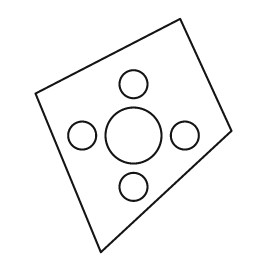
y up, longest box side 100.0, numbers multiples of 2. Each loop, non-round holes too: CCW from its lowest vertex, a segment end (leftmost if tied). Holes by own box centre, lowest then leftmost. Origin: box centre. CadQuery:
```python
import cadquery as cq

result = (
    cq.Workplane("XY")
    .moveTo(-14.0, -50.0)
    .lineTo(42.0, 2.0)
    .lineTo(20.0, 50.0)
    .lineTo(-42.0, 18.0)
    .close()
    .moveTo(0.0, -22.0)
    .circle(6.0)
    .moveTo(-22.0, 0.0)
    .circle(6.0)
    .moveTo(0.0, 0.0)
    .circle(12.0)
    .moveTo(22.0, 0.0)
    .circle(6.0)
    .moveTo(0.0, 22.0)
    .circle(6.0)
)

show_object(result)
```